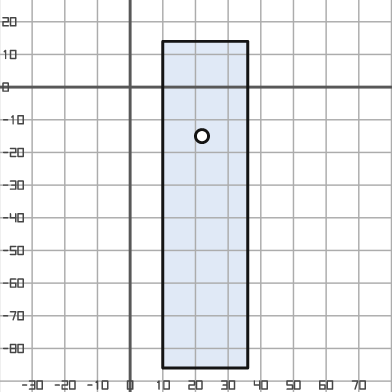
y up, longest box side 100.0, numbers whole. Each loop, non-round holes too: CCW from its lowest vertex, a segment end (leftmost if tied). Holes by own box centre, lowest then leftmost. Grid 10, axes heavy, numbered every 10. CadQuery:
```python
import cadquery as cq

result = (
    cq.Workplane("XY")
    .moveTo(10.0, -86.0)
    .lineTo(36.0, -86.0)
    .lineTo(36.0, 14.0)
    .lineTo(10.0, 14.0)
    .close()
    .moveTo(22.0, -15.0)
    .circle(2.0)
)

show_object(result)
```